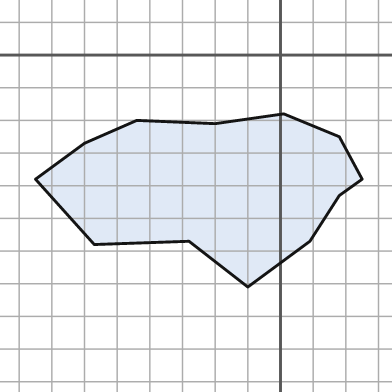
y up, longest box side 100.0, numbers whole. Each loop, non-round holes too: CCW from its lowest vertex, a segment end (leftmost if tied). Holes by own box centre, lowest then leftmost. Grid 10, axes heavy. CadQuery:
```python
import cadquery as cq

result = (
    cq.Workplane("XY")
    .moveTo(-10.0, -71.0)
    .lineTo(9.0, -57.0)
    .lineTo(18.0, -43.0)
    .lineTo(25.0, -38.0)
    .lineTo(18.0, -25.0)
    .lineTo(1.0, -18.0)
    .lineTo(-20.0, -21.0)
    .lineTo(-44.0, -20.0)
    .lineTo(-60.0, -27.0)
    .lineTo(-75.0, -38.0)
    .lineTo(-57.0, -58.0)
    .lineTo(-28.0, -57.0)
    .close()
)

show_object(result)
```